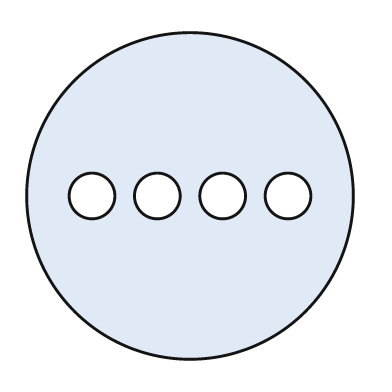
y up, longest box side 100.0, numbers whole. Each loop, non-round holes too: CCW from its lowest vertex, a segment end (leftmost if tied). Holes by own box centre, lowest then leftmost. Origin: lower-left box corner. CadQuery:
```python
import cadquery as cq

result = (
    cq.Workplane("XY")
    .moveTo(50.0, 50.0)
    .circle(50.0)
    .moveTo(20.0, 50.0)
    .circle(7.0)
    .moveTo(40.0, 50.0)
    .circle(7.0)
    .moveTo(60.0, 50.0)
    .circle(7.0)
    .moveTo(80.0, 50.0)
    .circle(7.0)
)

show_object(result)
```